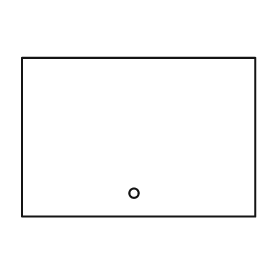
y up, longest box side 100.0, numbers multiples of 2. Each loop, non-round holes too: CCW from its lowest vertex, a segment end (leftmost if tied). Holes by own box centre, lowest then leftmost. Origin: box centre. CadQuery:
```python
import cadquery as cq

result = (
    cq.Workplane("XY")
    .moveTo(-50.0, -34.0)
    .lineTo(50.0, -34.0)
    .lineTo(50.0, 34.0)
    .lineTo(-50.0, 34.0)
    .close()
    .moveTo(-2.0, -24.0)
    .circle(2.0)
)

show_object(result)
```